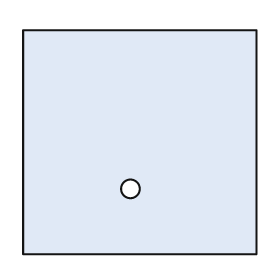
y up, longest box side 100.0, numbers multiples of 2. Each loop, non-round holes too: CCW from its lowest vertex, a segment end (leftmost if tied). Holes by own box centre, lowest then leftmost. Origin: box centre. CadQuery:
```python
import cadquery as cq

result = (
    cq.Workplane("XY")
    .moveTo(-50.0, -48.0)
    .lineTo(50.0, -48.0)
    .lineTo(50.0, 48.0)
    .lineTo(-50.0, 48.0)
    .close()
    .moveTo(-4.0, -20.0)
    .circle(4.0)
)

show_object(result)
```